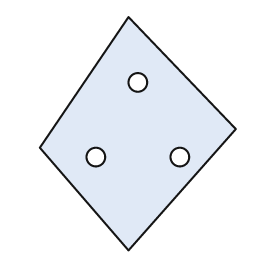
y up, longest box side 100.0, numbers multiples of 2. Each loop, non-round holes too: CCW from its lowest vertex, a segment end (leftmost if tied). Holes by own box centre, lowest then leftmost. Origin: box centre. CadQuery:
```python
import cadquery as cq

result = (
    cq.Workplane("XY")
    .moveTo(-4.0, -50.0)
    .lineTo(42.0, 2.0)
    .lineTo(-4.0, 50.0)
    .lineTo(-42.0, -6.0)
    .close()
    .moveTo(-18.0, -10.0)
    .circle(4.0)
    .moveTo(18.0, -10.0)
    .circle(4.0)
    .moveTo(0.0, 22.0)
    .circle(4.0)
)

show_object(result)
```